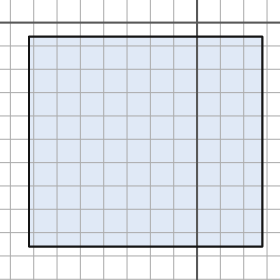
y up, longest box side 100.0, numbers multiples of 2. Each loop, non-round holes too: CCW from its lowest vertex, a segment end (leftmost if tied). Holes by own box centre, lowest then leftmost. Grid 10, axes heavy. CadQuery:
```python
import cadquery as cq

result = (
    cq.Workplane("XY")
    .moveTo(-72.0, -96.0)
    .lineTo(28.0, -96.0)
    .lineTo(28.0, -6.0)
    .lineTo(-72.0, -6.0)
    .close()
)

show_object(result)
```